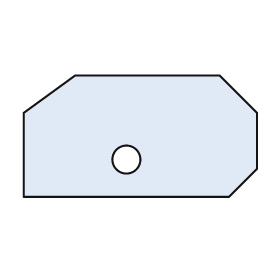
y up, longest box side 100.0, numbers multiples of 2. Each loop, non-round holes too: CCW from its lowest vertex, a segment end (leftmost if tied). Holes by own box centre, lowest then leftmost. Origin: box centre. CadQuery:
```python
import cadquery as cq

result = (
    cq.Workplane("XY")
    .moveTo(-50.0, -26.0)
    .lineTo(38.0, -26.0)
    .lineTo(50.0, -14.0)
    .lineTo(50.0, 10.0)
    .lineTo(34.0, 26.0)
    .lineTo(-28.0, 26.0)
    .lineTo(-50.0, 10.0)
    .close()
    .moveTo(-6.0, -10.0)
    .circle(6.0)
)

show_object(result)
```